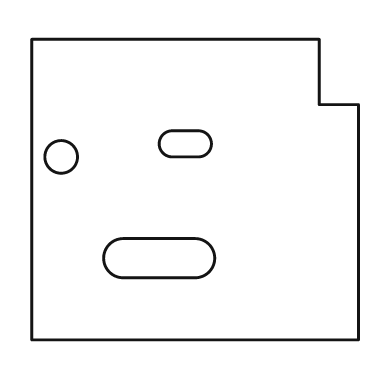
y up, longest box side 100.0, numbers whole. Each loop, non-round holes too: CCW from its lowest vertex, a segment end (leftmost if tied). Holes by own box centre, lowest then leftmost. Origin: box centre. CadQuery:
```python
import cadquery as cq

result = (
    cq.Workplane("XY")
    .moveTo(-50.0, -46.0)
    .lineTo(50.0, -46.0)
    .lineTo(50.0, 26.0)
    .lineTo(38.0, 26.0)
    .lineTo(38.0, 46.0)
    .lineTo(-50.0, 46.0)
    .close()
    .moveTo(-22.0, -27.0)
    .lineTo(0.0, -27.0)
    .threePointArc((6.0, -21.0), (0.0, -15.0))
    .lineTo(-22.0, -15.0)
    .threePointArc((-28.0, -21.0), (-22.0, -27.0))
    .close()
    .moveTo(-41.0, 10.0)
    .circle(5.0)
    .moveTo(-7.0, 10.0)
    .lineTo(1.0, 10.0)
    .threePointArc((5.0, 14.0), (1.0, 18.0))
    .lineTo(-7.0, 18.0)
    .threePointArc((-11.0, 14.0), (-7.0, 10.0))
    .close()
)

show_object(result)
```